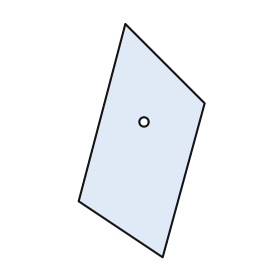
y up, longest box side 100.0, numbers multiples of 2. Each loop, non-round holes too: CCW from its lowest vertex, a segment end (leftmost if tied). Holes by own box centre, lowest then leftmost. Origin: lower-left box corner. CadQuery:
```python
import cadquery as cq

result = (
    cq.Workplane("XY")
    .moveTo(36.0, 0.0)
    .lineTo(54.0, 66.0)
    .lineTo(20.0, 100.0)
    .lineTo(0.0, 24.0)
    .close()
    .moveTo(28.0, 58.0)
    .circle(2.0)
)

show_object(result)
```